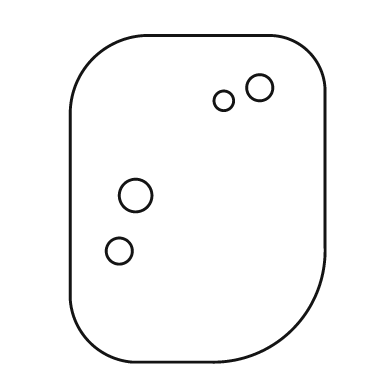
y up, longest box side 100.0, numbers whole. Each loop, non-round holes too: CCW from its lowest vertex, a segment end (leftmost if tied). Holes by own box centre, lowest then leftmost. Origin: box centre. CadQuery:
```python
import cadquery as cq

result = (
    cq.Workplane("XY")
    .moveTo(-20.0, -50.0)
    .lineTo(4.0, -50.0)
    .threePointArc((29.0, -40.0), (39.0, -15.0))
    .lineTo(39.0, 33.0)
    .threePointArc((34.0, 45.0), (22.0, 50.0))
    .lineTo(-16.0, 50.0)
    .threePointArc((-32.0, 43.0), (-39.0, 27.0))
    .lineTo(-39.0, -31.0)
    .threePointArc((-33.0, -44.0), (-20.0, -50.0))
    .close()
    .moveTo(-24.0, -16.0)
    .circle(4.0)
    .moveTo(-19.0, 1.0)
    .circle(5.0)
    .moveTo(8.0, 30.0)
    .circle(3.0)
    .moveTo(19.0, 34.0)
    .circle(4.0)
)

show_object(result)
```